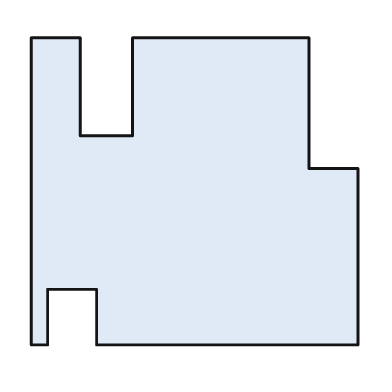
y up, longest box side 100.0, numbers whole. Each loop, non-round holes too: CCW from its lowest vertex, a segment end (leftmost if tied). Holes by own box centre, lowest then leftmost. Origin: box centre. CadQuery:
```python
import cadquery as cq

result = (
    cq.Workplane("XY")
    .moveTo(-50.0, -47.0)
    .lineTo(-45.0, -47.0)
    .lineTo(-45.0, -30.0)
    .lineTo(-30.0, -30.0)
    .lineTo(-30.0, -47.0)
    .lineTo(50.0, -47.0)
    .lineTo(50.0, 7.0)
    .lineTo(35.0, 7.0)
    .lineTo(35.0, 47.0)
    .lineTo(-19.0, 47.0)
    .lineTo(-19.0, 17.0)
    .lineTo(-35.0, 17.0)
    .lineTo(-35.0, 47.0)
    .lineTo(-50.0, 47.0)
    .close()
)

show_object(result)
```